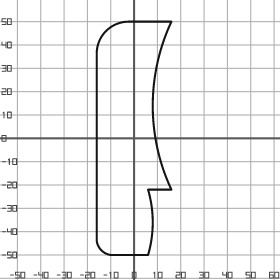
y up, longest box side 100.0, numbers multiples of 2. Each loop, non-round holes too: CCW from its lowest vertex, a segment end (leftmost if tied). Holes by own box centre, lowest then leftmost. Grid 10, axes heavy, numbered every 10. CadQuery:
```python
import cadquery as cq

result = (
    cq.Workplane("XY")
    .moveTo(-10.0, -50.0)
    .lineTo(6.0, -50.0)
    .threePointArc((8.0, -36.0), (6.0, -22.0))
    .lineTo(16.0, -22.0)
    .threePointArc((8.0, 14.0), (16.0, 50.0))
    .lineTo(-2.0, 50.0)
    .threePointArc((-12.0, 46.0), (-16.0, 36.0))
    .lineTo(-16.0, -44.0)
    .threePointArc((-14.0, -48.0), (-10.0, -50.0))
    .close()
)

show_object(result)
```